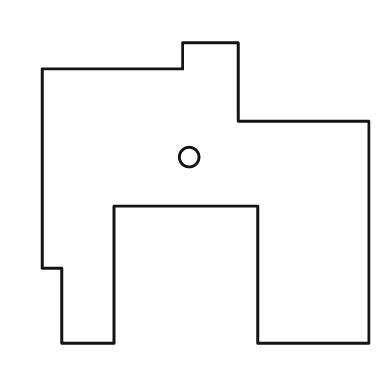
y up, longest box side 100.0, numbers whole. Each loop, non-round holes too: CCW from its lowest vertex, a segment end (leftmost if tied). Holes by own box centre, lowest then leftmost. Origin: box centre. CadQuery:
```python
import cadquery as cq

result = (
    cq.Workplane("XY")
    .moveTo(-44.0, -46.0)
    .lineTo(-28.0, -46.0)
    .lineTo(-28.0, -4.0)
    .lineTo(16.0, -4.0)
    .lineTo(16.0, -46.0)
    .lineTo(50.0, -46.0)
    .lineTo(50.0, 22.0)
    .lineTo(10.0, 22.0)
    .lineTo(10.0, 46.0)
    .lineTo(-7.0, 46.0)
    .lineTo(-7.0, 38.0)
    .lineTo(-50.0, 38.0)
    .lineTo(-50.0, -23.0)
    .lineTo(-44.0, -23.0)
    .close()
    .moveTo(-5.0, 11.0)
    .circle(3.0)
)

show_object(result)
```